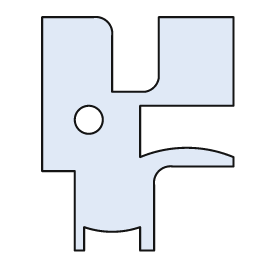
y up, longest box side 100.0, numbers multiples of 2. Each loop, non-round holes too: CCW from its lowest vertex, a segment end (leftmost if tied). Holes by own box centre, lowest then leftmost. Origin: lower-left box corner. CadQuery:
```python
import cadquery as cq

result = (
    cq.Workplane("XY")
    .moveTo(14.0, 0.0)
    .lineTo(18.0, 0.0)
    .lineTo(18.0, 10.0)
    .threePointArc((30.0, 8.0), (42.0, 10.0))
    .lineTo(42.0, 0.0)
    .lineTo(48.0, 0.0)
    .lineTo(48.0, 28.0)
    .threePointArc((50.0, 34.0), (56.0, 36.0))
    .lineTo(82.0, 36.0)
    .lineTo(82.0, 40.0)
    .threePointArc((62.0, 44.0), (42.0, 40.0))
    .lineTo(42.0, 62.0)
    .lineTo(82.0, 62.0)
    .lineTo(82.0, 100.0)
    .lineTo(50.0, 100.0)
    .lineTo(50.0, 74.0)
    .threePointArc((48.0, 70.0), (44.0, 68.0))
    .lineTo(30.0, 68.0)
    .lineTo(30.0, 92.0)
    .threePointArc((28.0, 98.0), (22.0, 100.0))
    .lineTo(0.0, 100.0)
    .lineTo(0.0, 34.0)
    .lineTo(14.0, 34.0)
    .close()
    .moveTo(20.0, 56.0)
    .circle(6.0)
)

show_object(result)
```